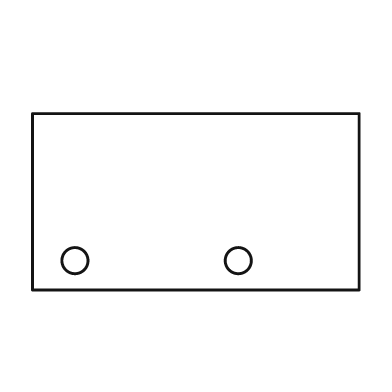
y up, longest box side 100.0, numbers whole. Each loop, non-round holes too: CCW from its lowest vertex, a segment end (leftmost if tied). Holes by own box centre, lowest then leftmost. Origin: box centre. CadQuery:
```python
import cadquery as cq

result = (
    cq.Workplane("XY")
    .moveTo(-50.0, -27.0)
    .lineTo(50.0, -27.0)
    .lineTo(50.0, 27.0)
    .lineTo(-50.0, 27.0)
    .close()
    .moveTo(-37.0, -18.0)
    .circle(4.0)
    .moveTo(13.0, -18.0)
    .circle(4.0)
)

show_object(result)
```